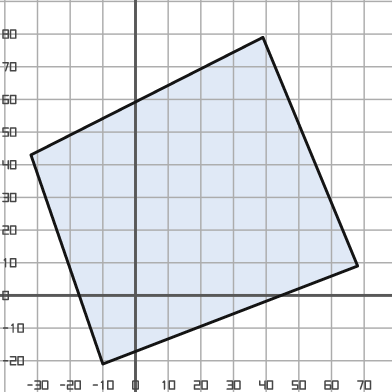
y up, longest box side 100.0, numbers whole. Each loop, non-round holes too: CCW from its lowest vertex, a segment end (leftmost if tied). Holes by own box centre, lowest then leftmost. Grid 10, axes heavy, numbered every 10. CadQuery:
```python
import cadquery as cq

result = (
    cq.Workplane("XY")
    .moveTo(-10.0, -21.0)
    .lineTo(68.0, 9.0)
    .lineTo(39.0, 79.0)
    .lineTo(-32.0, 43.0)
    .close()
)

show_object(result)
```